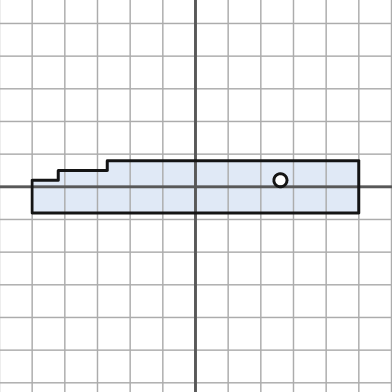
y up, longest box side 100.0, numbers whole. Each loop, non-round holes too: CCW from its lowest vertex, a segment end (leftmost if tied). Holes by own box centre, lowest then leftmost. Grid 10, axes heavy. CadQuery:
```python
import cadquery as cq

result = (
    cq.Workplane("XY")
    .moveTo(-50.0, -8.0)
    .lineTo(50.0, -8.0)
    .lineTo(50.0, 8.0)
    .lineTo(-27.0, 8.0)
    .lineTo(-27.0, 5.0)
    .lineTo(-42.0, 5.0)
    .lineTo(-42.0, 2.0)
    .lineTo(-50.0, 2.0)
    .close()
    .moveTo(26.0, 2.0)
    .circle(2.0)
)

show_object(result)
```